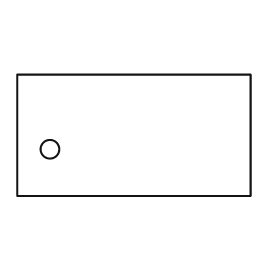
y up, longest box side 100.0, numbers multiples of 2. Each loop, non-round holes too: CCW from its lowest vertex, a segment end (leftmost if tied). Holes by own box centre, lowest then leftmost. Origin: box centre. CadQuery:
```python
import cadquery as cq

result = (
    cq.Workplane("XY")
    .moveTo(-50.0, -26.0)
    .lineTo(50.0, -26.0)
    .lineTo(50.0, 26.0)
    .lineTo(-50.0, 26.0)
    .close()
    .moveTo(-36.0, -6.0)
    .circle(4.0)
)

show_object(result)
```